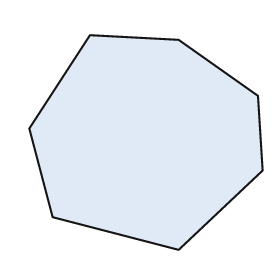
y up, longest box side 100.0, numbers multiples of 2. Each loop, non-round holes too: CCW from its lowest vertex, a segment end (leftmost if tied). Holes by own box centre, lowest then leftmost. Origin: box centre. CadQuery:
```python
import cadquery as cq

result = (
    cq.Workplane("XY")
    .moveTo(14.0, -46.0)
    .lineTo(50.0, -12.0)
    .lineTo(48.0, 20.0)
    .lineTo(14.0, 44.0)
    .lineTo(-24.0, 46.0)
    .lineTo(-50.0, 6.0)
    .lineTo(-40.0, -32.0)
    .close()
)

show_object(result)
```